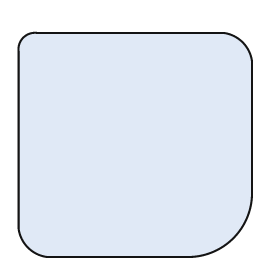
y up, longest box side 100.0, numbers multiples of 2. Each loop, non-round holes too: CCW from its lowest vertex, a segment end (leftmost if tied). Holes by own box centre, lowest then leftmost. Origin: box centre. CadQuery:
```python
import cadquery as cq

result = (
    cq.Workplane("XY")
    .moveTo(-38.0, -48.0)
    .lineTo(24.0, -48.0)
    .threePointArc((42.0, -40.0), (50.0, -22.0))
    .lineTo(50.0, 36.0)
    .threePointArc((46.0, 44.0), (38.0, 48.0))
    .lineTo(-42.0, 48.0)
    .threePointArc((-48.0, 46.0), (-50.0, 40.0))
    .lineTo(-50.0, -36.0)
    .threePointArc((-46.0, -44.0), (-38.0, -48.0))
    .close()
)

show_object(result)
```